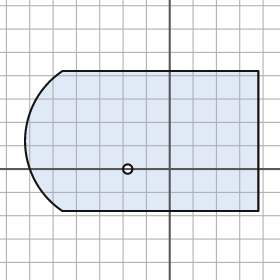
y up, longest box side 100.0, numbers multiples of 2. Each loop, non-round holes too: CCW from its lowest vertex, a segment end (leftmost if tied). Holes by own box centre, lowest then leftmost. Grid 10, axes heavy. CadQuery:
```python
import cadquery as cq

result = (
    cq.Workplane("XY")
    .moveTo(-46.0, -18.0)
    .lineTo(38.0, -18.0)
    .lineTo(38.0, 42.0)
    .lineTo(-46.0, 42.0)
    .threePointArc((-62.0, 12.0), (-46.0, -18.0))
    .close()
    .moveTo(-18.0, 0.0)
    .circle(2.0)
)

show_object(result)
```